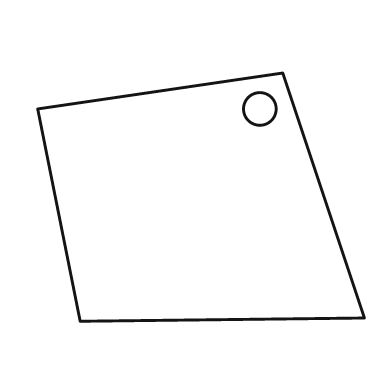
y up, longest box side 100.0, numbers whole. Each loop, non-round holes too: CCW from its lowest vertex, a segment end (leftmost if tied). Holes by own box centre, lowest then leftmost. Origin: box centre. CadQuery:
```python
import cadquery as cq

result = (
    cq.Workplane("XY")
    .moveTo(-37.0, -38.0)
    .lineTo(50.0, -37.0)
    .lineTo(25.0, 38.0)
    .lineTo(-50.0, 27.0)
    .close()
    .moveTo(18.0, 27.0)
    .circle(5.0)
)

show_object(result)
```